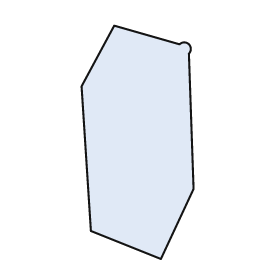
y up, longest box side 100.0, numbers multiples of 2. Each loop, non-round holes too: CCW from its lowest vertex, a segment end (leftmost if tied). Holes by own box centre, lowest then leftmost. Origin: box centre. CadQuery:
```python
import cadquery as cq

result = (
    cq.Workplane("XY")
    .moveTo(10.0, -50.0)
    .lineTo(24.0, -20.0)
    .lineTo(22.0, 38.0)
    .threePointArc((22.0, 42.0), (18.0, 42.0))
    .lineTo(-10.0, 50.0)
    .lineTo(-24.0, 24.0)
    .lineTo(-20.0, -38.0)
    .close()
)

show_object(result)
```